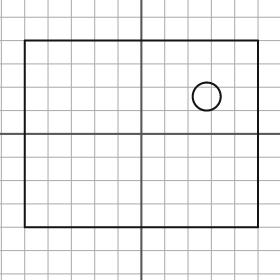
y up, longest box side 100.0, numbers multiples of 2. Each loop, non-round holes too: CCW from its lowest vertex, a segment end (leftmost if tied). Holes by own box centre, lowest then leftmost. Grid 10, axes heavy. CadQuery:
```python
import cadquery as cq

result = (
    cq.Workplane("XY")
    .moveTo(-50.0, -40.0)
    .lineTo(50.0, -40.0)
    .lineTo(50.0, 40.0)
    .lineTo(-50.0, 40.0)
    .close()
    .moveTo(28.0, 16.0)
    .circle(6.0)
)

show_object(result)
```